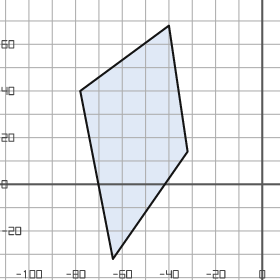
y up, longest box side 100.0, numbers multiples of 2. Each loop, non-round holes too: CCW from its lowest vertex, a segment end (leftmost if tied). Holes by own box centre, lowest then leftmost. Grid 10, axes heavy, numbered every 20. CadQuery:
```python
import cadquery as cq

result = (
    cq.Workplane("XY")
    .moveTo(-64.0, -32.0)
    .lineTo(-32.0, 14.0)
    .lineTo(-40.0, 68.0)
    .lineTo(-78.0, 40.0)
    .close()
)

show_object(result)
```